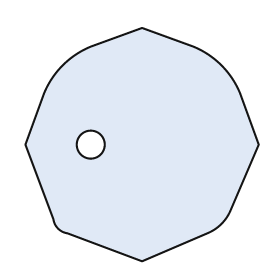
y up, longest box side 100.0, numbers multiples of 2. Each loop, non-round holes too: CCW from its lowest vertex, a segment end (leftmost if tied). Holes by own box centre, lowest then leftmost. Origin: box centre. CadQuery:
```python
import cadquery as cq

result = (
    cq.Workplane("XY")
    .moveTo(0.0, -50.0)
    .lineTo(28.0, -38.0)
    .threePointArc((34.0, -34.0), (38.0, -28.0))
    .lineTo(50.0, 0.0)
    .lineTo(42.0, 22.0)
    .threePointArc((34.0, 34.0), (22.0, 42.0))
    .lineTo(0.0, 50.0)
    .lineTo(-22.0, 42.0)
    .threePointArc((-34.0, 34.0), (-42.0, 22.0))
    .lineTo(-50.0, 0.0)
    .lineTo(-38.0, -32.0)
    .threePointArc((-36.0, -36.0), (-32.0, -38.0))
    .close()
    .moveTo(-22.0, 0.0)
    .circle(6.0)
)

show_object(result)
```